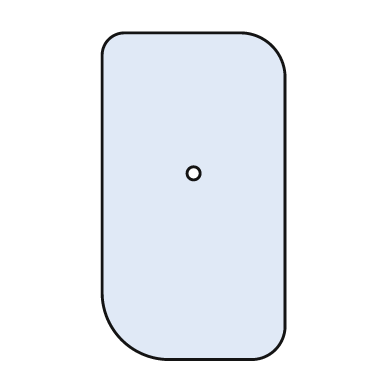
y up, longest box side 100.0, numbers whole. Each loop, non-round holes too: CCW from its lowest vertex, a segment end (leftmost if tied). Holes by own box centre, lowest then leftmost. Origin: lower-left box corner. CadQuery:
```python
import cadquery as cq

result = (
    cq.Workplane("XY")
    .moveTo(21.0, 0.0)
    .lineTo(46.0, 0.0)
    .threePointArc((53.0, 3.0), (56.0, 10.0))
    .lineTo(56.0, 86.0)
    .threePointArc((52.0, 96.0), (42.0, 100.0))
    .lineTo(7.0, 100.0)
    .threePointArc((2.0, 98.0), (0.0, 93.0))
    .lineTo(0.0, 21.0)
    .threePointArc((6.0, 6.0), (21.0, 0.0))
    .close()
    .moveTo(28.0, 57.0)
    .circle(2.0)
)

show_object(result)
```